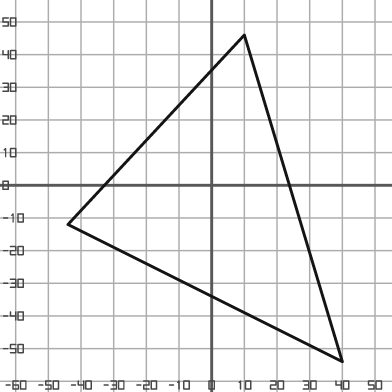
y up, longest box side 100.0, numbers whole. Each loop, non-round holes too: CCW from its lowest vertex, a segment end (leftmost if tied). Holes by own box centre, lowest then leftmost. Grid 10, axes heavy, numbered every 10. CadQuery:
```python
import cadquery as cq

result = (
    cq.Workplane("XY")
    .moveTo(40.0, -54.0)
    .lineTo(10.0, 46.0)
    .lineTo(-44.0, -12.0)
    .close()
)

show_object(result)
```